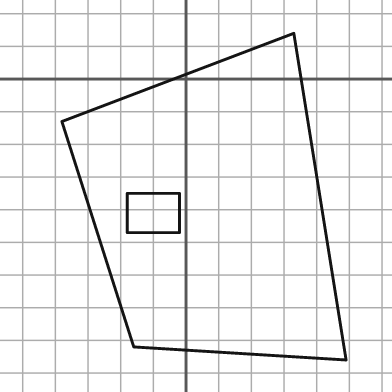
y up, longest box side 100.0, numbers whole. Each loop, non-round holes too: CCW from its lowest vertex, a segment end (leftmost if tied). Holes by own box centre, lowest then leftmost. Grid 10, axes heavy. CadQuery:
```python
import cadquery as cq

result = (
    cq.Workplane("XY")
    .moveTo(49.0, -86.0)
    .lineTo(33.0, 14.0)
    .lineTo(-38.0, -13.0)
    .lineTo(-16.0, -82.0)
    .close()
    .moveTo(-18.0, -47.0)
    .lineTo(-2.0, -47.0)
    .lineTo(-2.0, -35.0)
    .lineTo(-18.0, -35.0)
    .close()
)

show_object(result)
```